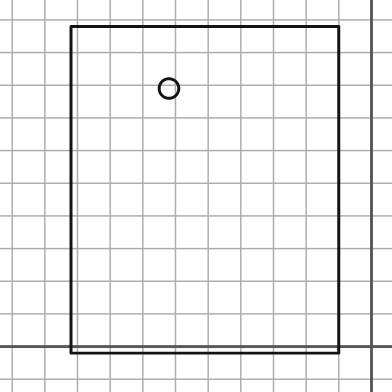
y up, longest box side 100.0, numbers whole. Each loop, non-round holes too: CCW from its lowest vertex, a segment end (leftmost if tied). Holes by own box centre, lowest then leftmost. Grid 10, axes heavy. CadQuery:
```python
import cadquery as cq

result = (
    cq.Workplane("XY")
    .moveTo(-92.0, -2.0)
    .lineTo(-10.0, -2.0)
    .lineTo(-10.0, 98.0)
    .lineTo(-92.0, 98.0)
    .close()
    .moveTo(-62.0, 79.0)
    .circle(3.0)
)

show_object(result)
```